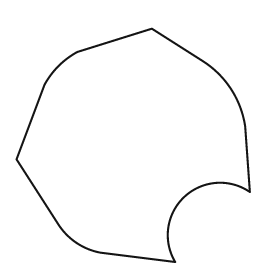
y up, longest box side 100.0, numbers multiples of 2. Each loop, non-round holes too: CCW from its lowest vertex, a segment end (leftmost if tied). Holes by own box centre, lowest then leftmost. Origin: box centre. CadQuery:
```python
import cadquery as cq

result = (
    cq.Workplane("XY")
    .moveTo(18.0, -50.0)
    .threePointArc((22.0, -22.0), (50.0, -20.0))
    .lineTo(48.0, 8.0)
    .threePointArc((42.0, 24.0), (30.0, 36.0))
    .lineTo(8.0, 50.0)
    .lineTo(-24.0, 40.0)
    .threePointArc((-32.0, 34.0), (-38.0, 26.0))
    .lineTo(-50.0, -6.0)
    .lineTo(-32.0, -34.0)
    .threePointArc((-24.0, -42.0), (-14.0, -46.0))
    .close()
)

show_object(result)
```